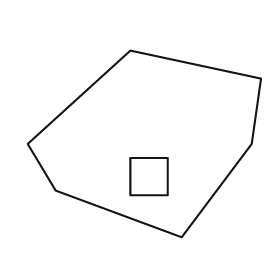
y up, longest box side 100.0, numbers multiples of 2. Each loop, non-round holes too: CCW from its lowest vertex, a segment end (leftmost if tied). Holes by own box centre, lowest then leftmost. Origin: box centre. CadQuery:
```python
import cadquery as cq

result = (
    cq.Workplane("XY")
    .moveTo(16.0, -40.0)
    .lineTo(46.0, 0.0)
    .lineTo(50.0, 28.0)
    .lineTo(-6.0, 40.0)
    .lineTo(-50.0, 0.0)
    .lineTo(-38.0, -20.0)
    .close()
    .moveTo(-6.0, -22.0)
    .lineTo(10.0, -22.0)
    .lineTo(10.0, -6.0)
    .lineTo(-6.0, -6.0)
    .close()
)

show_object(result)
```